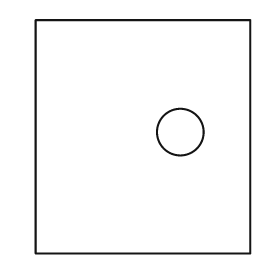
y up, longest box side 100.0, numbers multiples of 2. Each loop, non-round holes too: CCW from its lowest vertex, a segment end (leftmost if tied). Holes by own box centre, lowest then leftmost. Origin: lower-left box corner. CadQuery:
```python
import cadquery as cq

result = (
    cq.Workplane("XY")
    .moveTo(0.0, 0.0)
    .lineTo(92.0, 0.0)
    .lineTo(92.0, 100.0)
    .lineTo(0.0, 100.0)
    .close()
    .moveTo(62.0, 52.0)
    .circle(10.0)
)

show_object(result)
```